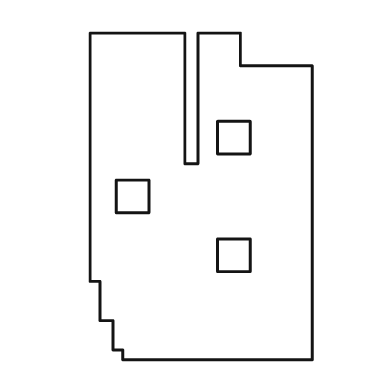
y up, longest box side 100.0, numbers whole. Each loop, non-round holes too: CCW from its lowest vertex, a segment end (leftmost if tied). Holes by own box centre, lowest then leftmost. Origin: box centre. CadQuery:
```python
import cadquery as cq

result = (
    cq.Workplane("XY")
    .moveTo(-24.0, -50.0)
    .lineTo(34.0, -50.0)
    .lineTo(34.0, 40.0)
    .lineTo(12.0, 40.0)
    .lineTo(12.0, 50.0)
    .lineTo(-1.0, 50.0)
    .lineTo(-1.0, 10.0)
    .lineTo(-5.0, 10.0)
    .lineTo(-5.0, 50.0)
    .lineTo(-34.0, 50.0)
    .lineTo(-34.0, -26.0)
    .lineTo(-31.0, -26.0)
    .lineTo(-31.0, -38.0)
    .lineTo(-27.0, -38.0)
    .lineTo(-27.0, -47.0)
    .lineTo(-24.0, -47.0)
    .close()
    .moveTo(5.0, -23.0)
    .lineTo(15.0, -23.0)
    .lineTo(15.0, -13.0)
    .lineTo(5.0, -13.0)
    .close()
    .moveTo(-26.0, -5.0)
    .lineTo(-16.0, -5.0)
    .lineTo(-16.0, 5.0)
    .lineTo(-26.0, 5.0)
    .close()
    .moveTo(5.0, 13.0)
    .lineTo(15.0, 13.0)
    .lineTo(15.0, 23.0)
    .lineTo(5.0, 23.0)
    .close()
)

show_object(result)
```